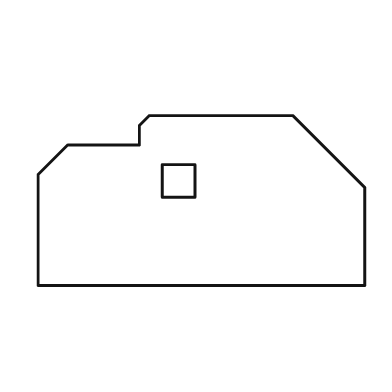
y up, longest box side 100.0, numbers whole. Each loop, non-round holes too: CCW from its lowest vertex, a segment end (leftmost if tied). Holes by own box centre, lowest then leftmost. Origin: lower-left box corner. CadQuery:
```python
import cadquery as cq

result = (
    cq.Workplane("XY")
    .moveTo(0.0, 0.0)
    .lineTo(100.0, 0.0)
    .lineTo(100.0, 30.0)
    .lineTo(78.0, 52.0)
    .lineTo(34.0, 52.0)
    .lineTo(31.0, 49.0)
    .lineTo(31.0, 43.0)
    .lineTo(9.0, 43.0)
    .lineTo(0.0, 34.0)
    .close()
    .moveTo(38.0, 27.0)
    .lineTo(48.0, 27.0)
    .lineTo(48.0, 37.0)
    .lineTo(38.0, 37.0)
    .close()
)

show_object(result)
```